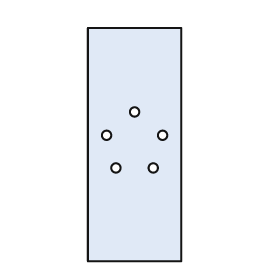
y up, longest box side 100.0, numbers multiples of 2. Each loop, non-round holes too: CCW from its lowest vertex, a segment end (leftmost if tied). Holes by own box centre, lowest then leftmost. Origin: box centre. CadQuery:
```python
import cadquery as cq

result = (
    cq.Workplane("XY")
    .moveTo(-20.0, -50.0)
    .lineTo(20.0, -50.0)
    .lineTo(20.0, 50.0)
    .lineTo(-20.0, 50.0)
    .close()
    .moveTo(-8.0, -10.0)
    .circle(2.0)
    .moveTo(8.0, -10.0)
    .circle(2.0)
    .moveTo(-12.0, 4.0)
    .circle(2.0)
    .moveTo(12.0, 4.0)
    .circle(2.0)
    .moveTo(0.0, 14.0)
    .circle(2.0)
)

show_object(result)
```